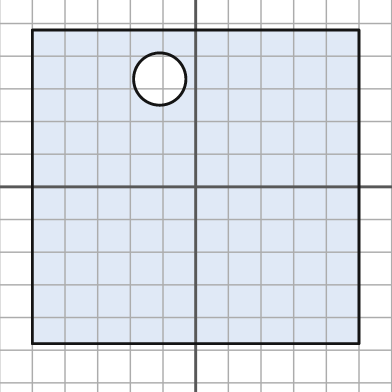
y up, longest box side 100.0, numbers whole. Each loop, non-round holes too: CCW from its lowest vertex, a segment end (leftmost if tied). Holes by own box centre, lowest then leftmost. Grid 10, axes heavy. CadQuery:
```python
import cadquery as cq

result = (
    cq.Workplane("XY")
    .moveTo(-50.0, -48.0)
    .lineTo(50.0, -48.0)
    .lineTo(50.0, 48.0)
    .lineTo(-50.0, 48.0)
    .close()
    .moveTo(-11.0, 33.0)
    .circle(8.0)
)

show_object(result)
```